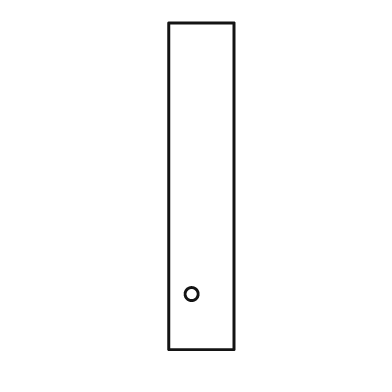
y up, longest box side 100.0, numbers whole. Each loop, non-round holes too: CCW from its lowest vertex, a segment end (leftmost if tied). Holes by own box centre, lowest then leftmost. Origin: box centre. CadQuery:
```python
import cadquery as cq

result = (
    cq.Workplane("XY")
    .moveTo(-10.0, -50.0)
    .lineTo(10.0, -50.0)
    .lineTo(10.0, 50.0)
    .lineTo(-10.0, 50.0)
    .close()
    .moveTo(-3.0, -33.0)
    .circle(2.0)
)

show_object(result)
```